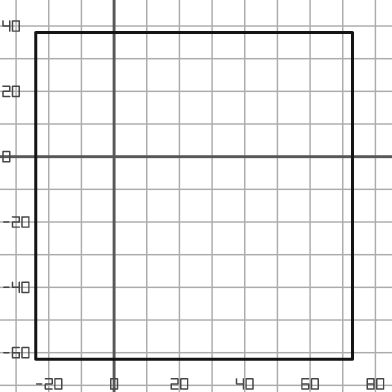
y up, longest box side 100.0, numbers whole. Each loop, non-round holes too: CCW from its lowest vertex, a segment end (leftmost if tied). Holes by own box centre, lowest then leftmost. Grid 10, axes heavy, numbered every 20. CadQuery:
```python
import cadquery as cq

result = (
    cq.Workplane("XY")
    .moveTo(-24.0, -62.0)
    .lineTo(73.0, -62.0)
    .lineTo(73.0, 38.0)
    .lineTo(-24.0, 38.0)
    .close()
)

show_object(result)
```